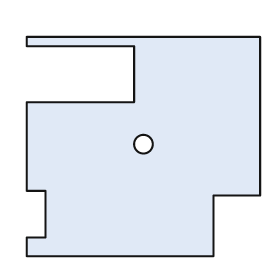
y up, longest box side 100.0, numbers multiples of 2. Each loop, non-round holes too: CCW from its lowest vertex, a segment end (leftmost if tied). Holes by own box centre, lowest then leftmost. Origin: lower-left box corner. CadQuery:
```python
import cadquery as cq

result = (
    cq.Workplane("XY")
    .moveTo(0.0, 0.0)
    .lineTo(80.0, 0.0)
    .lineTo(80.0, 26.0)
    .lineTo(100.0, 26.0)
    .lineTo(100.0, 94.0)
    .lineTo(0.0, 94.0)
    .lineTo(0.0, 90.0)
    .lineTo(46.0, 90.0)
    .lineTo(46.0, 66.0)
    .lineTo(0.0, 66.0)
    .lineTo(0.0, 28.0)
    .lineTo(8.0, 28.0)
    .lineTo(8.0, 8.0)
    .lineTo(0.0, 8.0)
    .close()
    .moveTo(50.0, 48.0)
    .circle(4.0)
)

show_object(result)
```